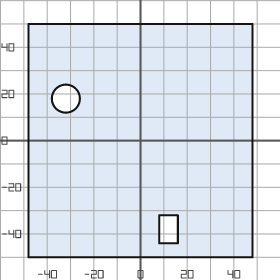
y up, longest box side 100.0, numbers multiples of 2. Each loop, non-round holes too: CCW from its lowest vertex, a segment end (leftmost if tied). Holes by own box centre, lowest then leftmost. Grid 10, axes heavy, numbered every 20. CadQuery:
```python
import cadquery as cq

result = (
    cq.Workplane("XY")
    .moveTo(-48.0, -50.0)
    .lineTo(48.0, -50.0)
    .lineTo(48.0, 50.0)
    .lineTo(-48.0, 50.0)
    .close()
    .moveTo(8.0, -44.0)
    .lineTo(16.0, -44.0)
    .lineTo(16.0, -32.0)
    .lineTo(8.0, -32.0)
    .close()
    .moveTo(-32.0, 18.0)
    .circle(6.0)
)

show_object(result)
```